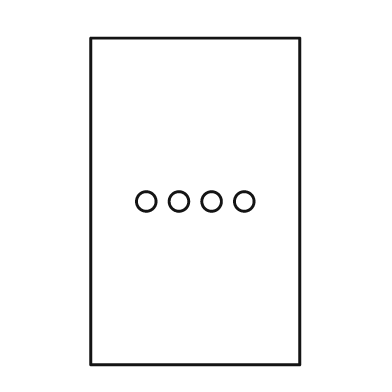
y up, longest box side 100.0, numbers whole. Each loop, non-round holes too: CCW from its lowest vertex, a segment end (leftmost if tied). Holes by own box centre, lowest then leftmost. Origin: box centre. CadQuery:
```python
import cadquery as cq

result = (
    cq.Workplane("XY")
    .moveTo(-32.0, -50.0)
    .lineTo(32.0, -50.0)
    .lineTo(32.0, 50.0)
    .lineTo(-32.0, 50.0)
    .close()
    .moveTo(-15.0, 0.0)
    .circle(3.0)
    .moveTo(-5.0, 0.0)
    .circle(3.0)
    .moveTo(5.0, 0.0)
    .circle(3.0)
    .moveTo(15.0, 0.0)
    .circle(3.0)
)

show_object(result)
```